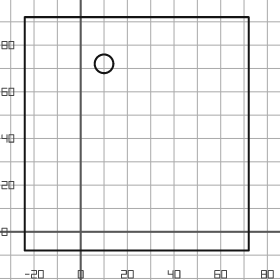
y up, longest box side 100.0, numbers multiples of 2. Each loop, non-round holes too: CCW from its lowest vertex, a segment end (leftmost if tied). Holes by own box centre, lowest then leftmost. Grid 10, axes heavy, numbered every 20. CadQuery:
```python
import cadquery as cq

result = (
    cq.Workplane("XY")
    .moveTo(-24.0, -8.0)
    .lineTo(72.0, -8.0)
    .lineTo(72.0, 92.0)
    .lineTo(-24.0, 92.0)
    .close()
    .moveTo(10.0, 72.0)
    .circle(4.0)
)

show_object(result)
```